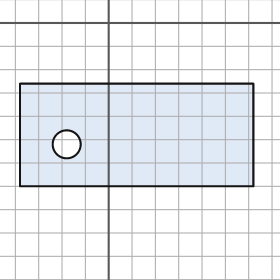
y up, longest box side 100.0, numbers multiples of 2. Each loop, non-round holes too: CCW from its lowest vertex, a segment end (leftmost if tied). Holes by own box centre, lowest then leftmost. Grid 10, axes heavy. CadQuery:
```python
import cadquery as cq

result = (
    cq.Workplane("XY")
    .moveTo(-38.0, -70.0)
    .lineTo(62.0, -70.0)
    .lineTo(62.0, -26.0)
    .lineTo(-38.0, -26.0)
    .close()
    .moveTo(-18.0, -52.0)
    .circle(6.0)
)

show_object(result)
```